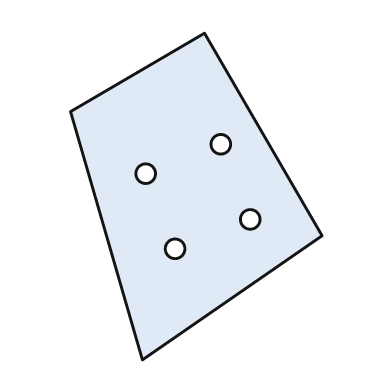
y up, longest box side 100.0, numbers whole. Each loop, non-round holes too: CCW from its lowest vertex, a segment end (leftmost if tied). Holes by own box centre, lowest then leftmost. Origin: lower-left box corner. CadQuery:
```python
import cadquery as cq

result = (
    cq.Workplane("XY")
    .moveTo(22.0, 0.0)
    .lineTo(77.0, 38.0)
    .lineTo(41.0, 100.0)
    .lineTo(0.0, 76.0)
    .close()
    .moveTo(32.0, 34.0)
    .circle(3.0)
    .moveTo(55.0, 43.0)
    .circle(3.0)
    .moveTo(23.0, 57.0)
    .circle(3.0)
    .moveTo(46.0, 66.0)
    .circle(3.0)
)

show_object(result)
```